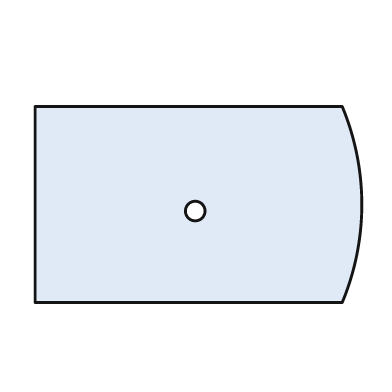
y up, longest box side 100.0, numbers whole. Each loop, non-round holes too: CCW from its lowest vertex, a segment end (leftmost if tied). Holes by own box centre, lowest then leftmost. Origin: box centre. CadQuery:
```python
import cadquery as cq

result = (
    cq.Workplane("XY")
    .moveTo(-50.0, -30.0)
    .lineTo(44.0, -30.0)
    .threePointArc((50.0, 0.0), (44.0, 30.0))
    .lineTo(-50.0, 30.0)
    .close()
    .moveTo(-1.0, -2.0)
    .circle(3.0)
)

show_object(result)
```